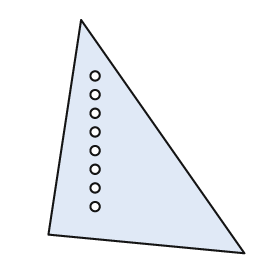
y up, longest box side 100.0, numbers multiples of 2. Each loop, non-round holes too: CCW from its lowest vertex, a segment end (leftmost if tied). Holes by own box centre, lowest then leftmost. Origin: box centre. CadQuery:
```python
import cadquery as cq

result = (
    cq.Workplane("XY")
    .moveTo(42.0, -50.0)
    .lineTo(-28.0, 50.0)
    .lineTo(-42.0, -42.0)
    .close()
    .moveTo(-22.0, -30.0)
    .circle(2.0)
    .moveTo(-22.0, -22.0)
    .circle(2.0)
    .moveTo(-22.0, -14.0)
    .circle(2.0)
    .moveTo(-22.0, -6.0)
    .circle(2.0)
    .moveTo(-22.0, 2.0)
    .circle(2.0)
    .moveTo(-22.0, 10.0)
    .circle(2.0)
    .moveTo(-22.0, 18.0)
    .circle(2.0)
    .moveTo(-22.0, 26.0)
    .circle(2.0)
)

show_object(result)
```